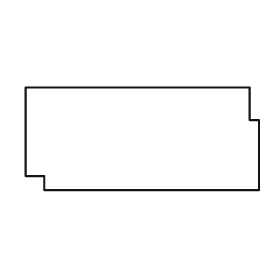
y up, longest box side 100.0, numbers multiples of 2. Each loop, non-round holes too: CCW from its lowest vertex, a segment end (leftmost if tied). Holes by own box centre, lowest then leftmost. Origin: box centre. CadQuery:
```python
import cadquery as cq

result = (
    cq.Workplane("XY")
    .moveTo(-42.0, -22.0)
    .lineTo(50.0, -22.0)
    .lineTo(50.0, 8.0)
    .lineTo(46.0, 8.0)
    .lineTo(46.0, 22.0)
    .lineTo(-50.0, 22.0)
    .lineTo(-50.0, -16.0)
    .lineTo(-42.0, -16.0)
    .close()
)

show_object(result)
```